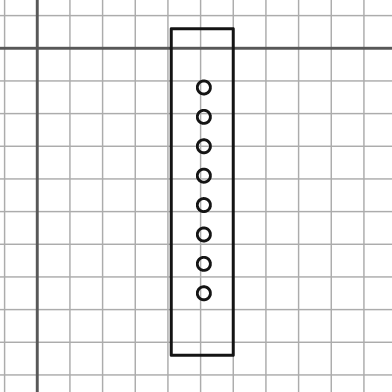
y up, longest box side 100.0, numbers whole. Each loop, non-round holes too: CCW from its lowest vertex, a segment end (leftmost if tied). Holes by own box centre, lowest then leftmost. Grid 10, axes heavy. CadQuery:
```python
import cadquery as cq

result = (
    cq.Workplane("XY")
    .moveTo(41.0, -94.0)
    .lineTo(60.0, -94.0)
    .lineTo(60.0, 6.0)
    .lineTo(41.0, 6.0)
    .close()
    .moveTo(51.0, -75.0)
    .circle(2.0)
    .moveTo(51.0, -66.0)
    .circle(2.0)
    .moveTo(51.0, -57.0)
    .circle(2.0)
    .moveTo(51.0, -48.0)
    .circle(2.0)
    .moveTo(51.0, -39.0)
    .circle(2.0)
    .moveTo(51.0, -30.0)
    .circle(2.0)
    .moveTo(51.0, -21.0)
    .circle(2.0)
    .moveTo(51.0, -12.0)
    .circle(2.0)
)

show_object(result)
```